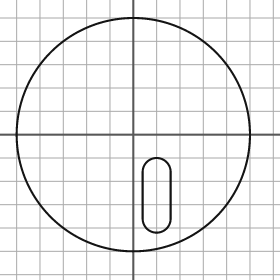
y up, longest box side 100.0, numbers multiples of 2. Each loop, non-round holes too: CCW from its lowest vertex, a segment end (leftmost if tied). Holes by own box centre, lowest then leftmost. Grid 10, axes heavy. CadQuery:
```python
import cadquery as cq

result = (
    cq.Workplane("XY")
    .moveTo(0.0, 0.0)
    .circle(50.0)
    .moveTo(4.0, -36.0)
    .threePointArc((10.0, -42.0), (16.0, -36.0))
    .lineTo(16.0, -16.0)
    .threePointArc((10.0, -10.0), (4.0, -16.0))
    .close()
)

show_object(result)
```